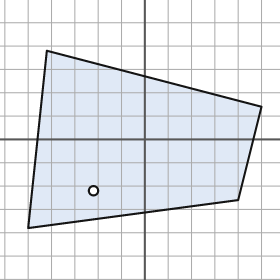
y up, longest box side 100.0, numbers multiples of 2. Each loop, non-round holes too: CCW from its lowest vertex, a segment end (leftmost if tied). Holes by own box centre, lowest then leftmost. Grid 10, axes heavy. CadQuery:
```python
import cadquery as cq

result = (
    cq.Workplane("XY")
    .moveTo(-50.0, -38.0)
    .lineTo(40.0, -26.0)
    .lineTo(50.0, 14.0)
    .lineTo(-42.0, 38.0)
    .close()
    .moveTo(-22.0, -22.0)
    .circle(2.0)
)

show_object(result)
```